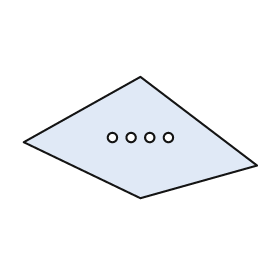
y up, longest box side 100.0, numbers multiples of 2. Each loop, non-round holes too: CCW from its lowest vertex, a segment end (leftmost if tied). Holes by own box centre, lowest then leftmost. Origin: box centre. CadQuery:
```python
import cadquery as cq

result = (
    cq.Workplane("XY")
    .moveTo(0.0, -26.0)
    .lineTo(50.0, -12.0)
    .lineTo(0.0, 26.0)
    .lineTo(-50.0, -2.0)
    .close()
    .moveTo(-12.0, 0.0)
    .circle(2.0)
    .moveTo(-4.0, 0.0)
    .circle(2.0)
    .moveTo(4.0, 0.0)
    .circle(2.0)
    .moveTo(12.0, 0.0)
    .circle(2.0)
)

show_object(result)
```